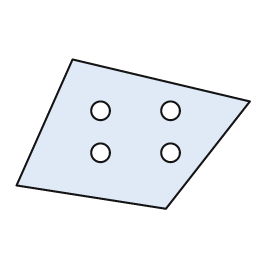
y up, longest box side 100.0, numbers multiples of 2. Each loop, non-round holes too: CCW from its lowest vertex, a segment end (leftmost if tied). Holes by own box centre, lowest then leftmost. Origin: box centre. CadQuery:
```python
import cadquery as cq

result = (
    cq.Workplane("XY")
    .moveTo(14.0, -32.0)
    .lineTo(50.0, 14.0)
    .lineTo(-26.0, 32.0)
    .lineTo(-50.0, -22.0)
    .close()
    .moveTo(-14.0, -8.0)
    .circle(4.0)
    .moveTo(16.0, -8.0)
    .circle(4.0)
    .moveTo(-14.0, 10.0)
    .circle(4.0)
    .moveTo(16.0, 10.0)
    .circle(4.0)
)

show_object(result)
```